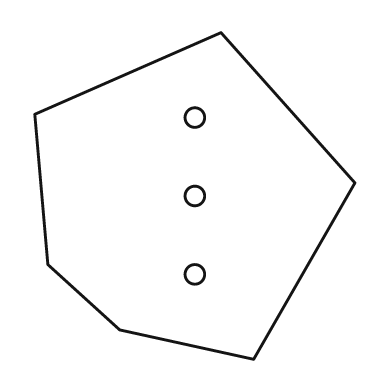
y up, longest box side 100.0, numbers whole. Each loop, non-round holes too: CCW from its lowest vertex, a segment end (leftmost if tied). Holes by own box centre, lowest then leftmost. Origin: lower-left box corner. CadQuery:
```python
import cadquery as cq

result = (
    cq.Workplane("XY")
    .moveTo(67.0, 0.0)
    .lineTo(98.0, 54.0)
    .lineTo(57.0, 100.0)
    .lineTo(0.0, 75.0)
    .lineTo(4.0, 29.0)
    .lineTo(26.0, 9.0)
    .close()
    .moveTo(49.0, 26.0)
    .circle(3.0)
    .moveTo(49.0, 50.0)
    .circle(3.0)
    .moveTo(49.0, 74.0)
    .circle(3.0)
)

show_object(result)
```